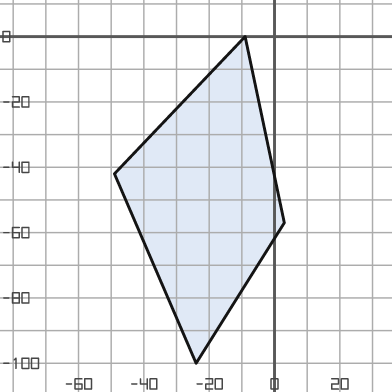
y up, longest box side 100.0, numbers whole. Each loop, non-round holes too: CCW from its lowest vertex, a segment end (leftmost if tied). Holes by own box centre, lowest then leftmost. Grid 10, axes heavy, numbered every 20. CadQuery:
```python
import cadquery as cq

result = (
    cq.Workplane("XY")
    .moveTo(-24.0, -100.0)
    .lineTo(3.0, -57.0)
    .lineTo(-9.0, 0.0)
    .lineTo(-49.0, -42.0)
    .close()
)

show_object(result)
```